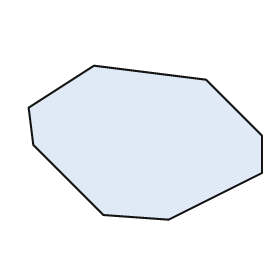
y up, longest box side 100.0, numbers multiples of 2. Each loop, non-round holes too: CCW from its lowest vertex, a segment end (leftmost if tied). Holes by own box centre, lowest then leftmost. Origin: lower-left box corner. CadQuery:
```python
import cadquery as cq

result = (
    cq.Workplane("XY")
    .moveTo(60.0, 0.0)
    .lineTo(100.0, 20.0)
    .lineTo(100.0, 36.0)
    .lineTo(76.0, 60.0)
    .lineTo(28.0, 66.0)
    .lineTo(0.0, 48.0)
    .lineTo(2.0, 32.0)
    .lineTo(32.0, 2.0)
    .close()
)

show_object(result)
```